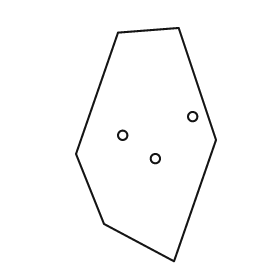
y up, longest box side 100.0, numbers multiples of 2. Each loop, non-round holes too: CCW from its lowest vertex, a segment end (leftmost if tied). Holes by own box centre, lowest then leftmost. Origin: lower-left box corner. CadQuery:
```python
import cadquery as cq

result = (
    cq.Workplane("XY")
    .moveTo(42.0, 0.0)
    .lineTo(60.0, 52.0)
    .lineTo(44.0, 100.0)
    .lineTo(18.0, 98.0)
    .lineTo(0.0, 46.0)
    .lineTo(12.0, 16.0)
    .close()
    .moveTo(34.0, 44.0)
    .circle(2.0)
    .moveTo(20.0, 54.0)
    .circle(2.0)
    .moveTo(50.0, 62.0)
    .circle(2.0)
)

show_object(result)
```